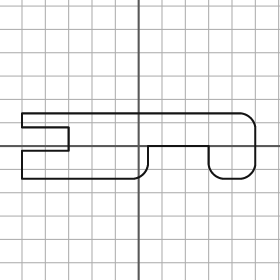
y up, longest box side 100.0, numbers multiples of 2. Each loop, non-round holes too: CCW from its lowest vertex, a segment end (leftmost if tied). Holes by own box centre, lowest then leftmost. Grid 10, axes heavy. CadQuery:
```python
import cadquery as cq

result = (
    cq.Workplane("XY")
    .moveTo(-50.0, -14.0)
    .lineTo(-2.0, -14.0)
    .threePointArc((2.0, -12.0), (4.0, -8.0))
    .lineTo(4.0, 0.0)
    .lineTo(30.0, 0.0)
    .lineTo(30.0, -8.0)
    .threePointArc((32.0, -12.0), (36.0, -14.0))
    .lineTo(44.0, -14.0)
    .threePointArc((48.0, -12.0), (50.0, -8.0))
    .lineTo(50.0, 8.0)
    .threePointArc((48.0, 12.0), (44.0, 14.0))
    .lineTo(-50.0, 14.0)
    .lineTo(-50.0, 8.0)
    .lineTo(-30.0, 8.0)
    .lineTo(-30.0, -2.0)
    .lineTo(-50.0, -2.0)
    .close()
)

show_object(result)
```